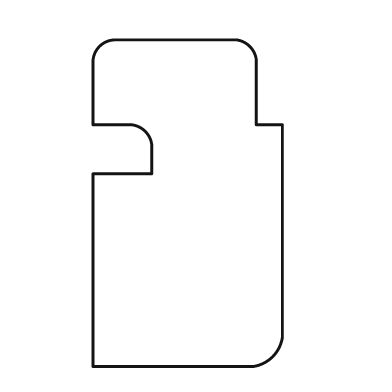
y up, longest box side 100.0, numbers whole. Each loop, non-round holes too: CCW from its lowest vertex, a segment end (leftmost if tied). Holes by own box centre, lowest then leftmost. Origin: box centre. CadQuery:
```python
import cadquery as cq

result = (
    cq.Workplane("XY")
    .moveTo(-29.0, -50.0)
    .lineTo(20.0, -50.0)
    .threePointArc((26.0, -47.0), (29.0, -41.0))
    .lineTo(29.0, 24.0)
    .lineTo(21.0, 24.0)
    .lineTo(21.0, 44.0)
    .threePointArc((19.0, 48.0), (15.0, 50.0))
    .lineTo(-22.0, 50.0)
    .threePointArc((-27.0, 48.0), (-29.0, 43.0))
    .lineTo(-29.0, 24.0)
    .lineTo(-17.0, 24.0)
    .threePointArc((-13.0, 22.0), (-11.0, 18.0))
    .lineTo(-11.0, 9.0)
    .lineTo(-29.0, 9.0)
    .close()
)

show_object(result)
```